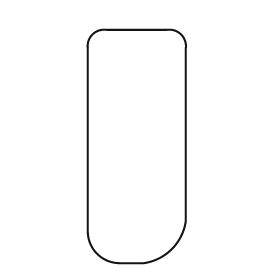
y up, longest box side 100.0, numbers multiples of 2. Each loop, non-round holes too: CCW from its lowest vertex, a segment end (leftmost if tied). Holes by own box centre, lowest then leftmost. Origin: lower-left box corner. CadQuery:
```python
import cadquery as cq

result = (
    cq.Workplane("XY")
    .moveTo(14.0, 0.0)
    .lineTo(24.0, 0.0)
    .threePointArc((36.0, 6.0), (42.0, 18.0))
    .lineTo(42.0, 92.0)
    .threePointArc((40.0, 98.0), (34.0, 100.0))
    .lineTo(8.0, 100.0)
    .threePointArc((2.0, 98.0), (0.0, 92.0))
    .lineTo(0.0, 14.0)
    .threePointArc((4.0, 4.0), (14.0, 0.0))
    .close()
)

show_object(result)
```